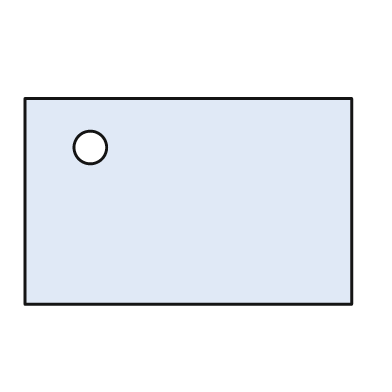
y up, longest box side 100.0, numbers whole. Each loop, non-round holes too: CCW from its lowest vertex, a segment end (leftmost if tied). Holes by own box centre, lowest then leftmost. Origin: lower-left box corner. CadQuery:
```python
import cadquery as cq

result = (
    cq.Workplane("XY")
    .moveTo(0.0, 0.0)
    .lineTo(100.0, 0.0)
    .lineTo(100.0, 63.0)
    .lineTo(0.0, 63.0)
    .close()
    .moveTo(20.0, 48.0)
    .circle(5.0)
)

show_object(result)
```